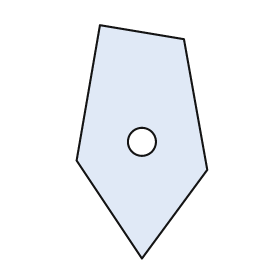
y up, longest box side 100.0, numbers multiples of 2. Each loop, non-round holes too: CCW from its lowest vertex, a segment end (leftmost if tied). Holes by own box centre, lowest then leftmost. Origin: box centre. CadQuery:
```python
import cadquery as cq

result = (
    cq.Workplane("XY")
    .moveTo(0.0, -50.0)
    .lineTo(28.0, -12.0)
    .lineTo(18.0, 44.0)
    .lineTo(-18.0, 50.0)
    .lineTo(-28.0, -8.0)
    .close()
    .moveTo(0.0, 0.0)
    .circle(6.0)
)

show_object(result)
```